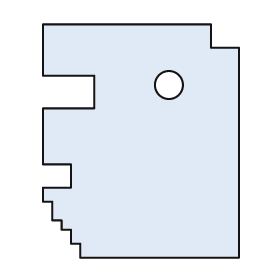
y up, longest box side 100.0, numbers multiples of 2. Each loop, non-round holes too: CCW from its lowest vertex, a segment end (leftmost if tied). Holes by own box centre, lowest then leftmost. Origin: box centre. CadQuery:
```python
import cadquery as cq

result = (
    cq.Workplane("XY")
    .moveTo(-26.0, -50.0)
    .lineTo(42.0, -50.0)
    .lineTo(42.0, 40.0)
    .lineTo(30.0, 40.0)
    .lineTo(30.0, 50.0)
    .lineTo(-42.0, 50.0)
    .lineTo(-42.0, 28.0)
    .lineTo(-20.0, 28.0)
    .lineTo(-20.0, 14.0)
    .lineTo(-42.0, 14.0)
    .lineTo(-42.0, -10.0)
    .lineTo(-30.0, -10.0)
    .lineTo(-30.0, -20.0)
    .lineTo(-42.0, -20.0)
    .lineTo(-42.0, -26.0)
    .lineTo(-38.0, -26.0)
    .lineTo(-38.0, -34.0)
    .lineTo(-34.0, -34.0)
    .lineTo(-34.0, -38.0)
    .lineTo(-30.0, -38.0)
    .lineTo(-30.0, -44.0)
    .lineTo(-26.0, -44.0)
    .close()
    .moveTo(12.0, 24.0)
    .circle(6.0)
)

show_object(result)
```